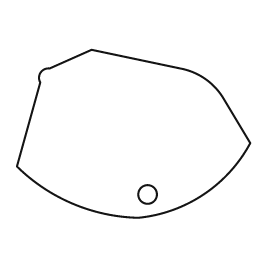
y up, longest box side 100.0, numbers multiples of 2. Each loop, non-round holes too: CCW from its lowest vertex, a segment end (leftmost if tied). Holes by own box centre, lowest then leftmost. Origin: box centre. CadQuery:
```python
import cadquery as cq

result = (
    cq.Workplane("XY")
    .moveTo(2.0, -36.0)
    .threePointArc((30.0, -26.0), (50.0, -4.0))
    .lineTo(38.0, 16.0)
    .threePointArc((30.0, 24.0), (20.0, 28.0))
    .lineTo(-18.0, 36.0)
    .lineTo(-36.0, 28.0)
    .threePointArc((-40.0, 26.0), (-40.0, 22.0))
    .lineTo(-50.0, -14.0)
    .threePointArc((-26.0, -30.0), (2.0, -36.0))
    .close()
    .moveTo(6.0, -26.0)
    .circle(4.0)
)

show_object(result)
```